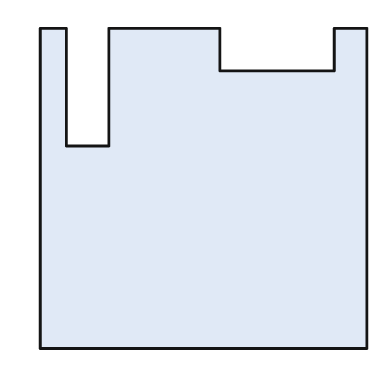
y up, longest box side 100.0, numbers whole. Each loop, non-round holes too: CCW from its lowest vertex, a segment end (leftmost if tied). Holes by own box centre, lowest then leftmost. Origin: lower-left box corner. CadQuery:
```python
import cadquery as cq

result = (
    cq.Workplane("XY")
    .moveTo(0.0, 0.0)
    .lineTo(100.0, 0.0)
    .lineTo(100.0, 98.0)
    .lineTo(90.0, 98.0)
    .lineTo(90.0, 85.0)
    .lineTo(55.0, 85.0)
    .lineTo(55.0, 98.0)
    .lineTo(21.0, 98.0)
    .lineTo(21.0, 62.0)
    .lineTo(8.0, 62.0)
    .lineTo(8.0, 98.0)
    .lineTo(0.0, 98.0)
    .close()
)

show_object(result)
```